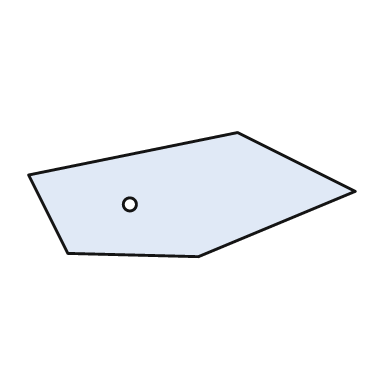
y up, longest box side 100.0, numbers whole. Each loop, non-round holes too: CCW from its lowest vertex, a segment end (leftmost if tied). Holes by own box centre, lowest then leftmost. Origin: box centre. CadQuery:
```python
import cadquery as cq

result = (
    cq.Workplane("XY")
    .moveTo(2.0, -19.0)
    .lineTo(50.0, 1.0)
    .lineTo(14.0, 19.0)
    .lineTo(-50.0, 6.0)
    .lineTo(-38.0, -18.0)
    .close()
    .moveTo(-19.0, -3.0)
    .circle(2.0)
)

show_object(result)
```